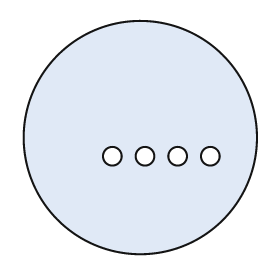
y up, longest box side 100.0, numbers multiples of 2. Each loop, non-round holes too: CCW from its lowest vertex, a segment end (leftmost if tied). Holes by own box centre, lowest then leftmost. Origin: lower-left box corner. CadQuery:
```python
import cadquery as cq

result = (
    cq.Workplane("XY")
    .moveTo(50.0, 50.0)
    .circle(50.0)
    .moveTo(38.0, 42.0)
    .circle(4.0)
    .moveTo(52.0, 42.0)
    .circle(4.0)
    .moveTo(66.0, 42.0)
    .circle(4.0)
    .moveTo(80.0, 42.0)
    .circle(4.0)
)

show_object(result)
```